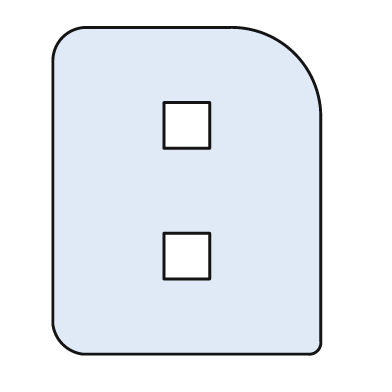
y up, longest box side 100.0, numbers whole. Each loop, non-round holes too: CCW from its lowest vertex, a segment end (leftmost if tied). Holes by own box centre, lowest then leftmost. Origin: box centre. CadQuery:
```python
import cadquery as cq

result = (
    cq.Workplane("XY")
    .moveTo(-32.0, -50.0)
    .lineTo(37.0, -50.0)
    .threePointArc((40.0, -49.0), (41.0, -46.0))
    .lineTo(41.0, 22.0)
    .threePointArc((33.0, 42.0), (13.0, 50.0))
    .lineTo(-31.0, 50.0)
    .threePointArc((-38.0, 47.0), (-41.0, 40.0))
    .lineTo(-41.0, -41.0)
    .threePointArc((-38.0, -47.0), (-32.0, -50.0))
    .close()
    .moveTo(-7.0, -27.0)
    .lineTo(7.0, -27.0)
    .lineTo(7.0, -13.0)
    .lineTo(-7.0, -13.0)
    .close()
    .moveTo(-7.0, 13.0)
    .lineTo(7.0, 13.0)
    .lineTo(7.0, 27.0)
    .lineTo(-7.0, 27.0)
    .close()
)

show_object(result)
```